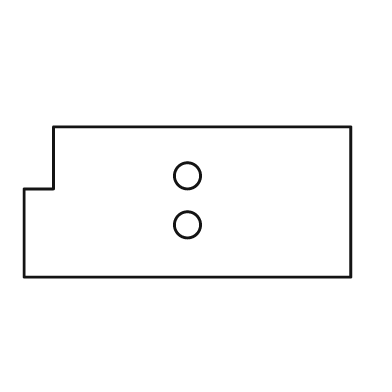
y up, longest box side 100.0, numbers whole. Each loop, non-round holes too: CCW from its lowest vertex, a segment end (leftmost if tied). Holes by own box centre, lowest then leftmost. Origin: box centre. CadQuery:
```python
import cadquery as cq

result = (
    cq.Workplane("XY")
    .moveTo(-50.0, -23.0)
    .lineTo(50.0, -23.0)
    .lineTo(50.0, 23.0)
    .lineTo(-41.0, 23.0)
    .lineTo(-41.0, 4.0)
    .lineTo(-50.0, 4.0)
    .close()
    .moveTo(0.0, -7.0)
    .circle(4.0)
    .moveTo(0.0, 8.0)
    .circle(4.0)
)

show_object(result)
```